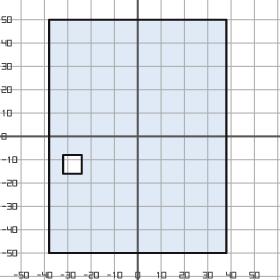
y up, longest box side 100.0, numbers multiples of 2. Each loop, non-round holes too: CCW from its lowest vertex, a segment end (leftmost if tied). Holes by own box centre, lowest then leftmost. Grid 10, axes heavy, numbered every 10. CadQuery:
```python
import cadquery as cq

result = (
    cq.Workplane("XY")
    .moveTo(-38.0, -50.0)
    .lineTo(38.0, -50.0)
    .lineTo(38.0, 50.0)
    .lineTo(-38.0, 50.0)
    .close()
    .moveTo(-32.0, -16.0)
    .lineTo(-24.0, -16.0)
    .lineTo(-24.0, -8.0)
    .lineTo(-32.0, -8.0)
    .close()
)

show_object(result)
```